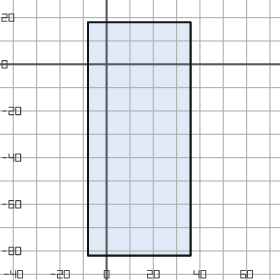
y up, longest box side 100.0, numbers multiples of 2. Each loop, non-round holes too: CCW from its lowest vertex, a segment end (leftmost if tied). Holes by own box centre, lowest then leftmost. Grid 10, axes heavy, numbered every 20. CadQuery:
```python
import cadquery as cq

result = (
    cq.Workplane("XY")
    .moveTo(-8.0, -82.0)
    .lineTo(36.0, -82.0)
    .lineTo(36.0, 18.0)
    .lineTo(-8.0, 18.0)
    .close()
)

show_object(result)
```